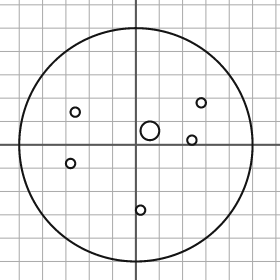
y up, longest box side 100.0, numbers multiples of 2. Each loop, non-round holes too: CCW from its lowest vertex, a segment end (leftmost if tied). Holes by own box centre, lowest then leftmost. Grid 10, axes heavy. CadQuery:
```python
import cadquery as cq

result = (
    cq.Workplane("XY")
    .moveTo(0.0, 0.0)
    .circle(50.0)
    .moveTo(2.0, -28.0)
    .circle(2.0)
    .moveTo(-28.0, -8.0)
    .circle(2.0)
    .moveTo(24.0, 2.0)
    .circle(2.0)
    .moveTo(6.0, 6.0)
    .circle(4.0)
    .moveTo(-26.0, 14.0)
    .circle(2.0)
    .moveTo(28.0, 18.0)
    .circle(2.0)
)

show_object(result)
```